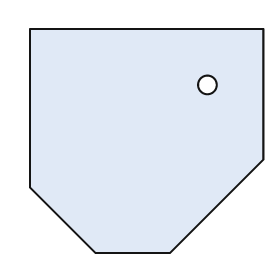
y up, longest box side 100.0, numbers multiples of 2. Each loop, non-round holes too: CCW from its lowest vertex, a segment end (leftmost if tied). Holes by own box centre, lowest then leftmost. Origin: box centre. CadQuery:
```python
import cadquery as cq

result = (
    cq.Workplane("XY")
    .moveTo(-22.0, -48.0)
    .lineTo(10.0, -48.0)
    .lineTo(50.0, -8.0)
    .lineTo(50.0, 48.0)
    .lineTo(-50.0, 48.0)
    .lineTo(-50.0, -20.0)
    .close()
    .moveTo(26.0, 24.0)
    .circle(4.0)
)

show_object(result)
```